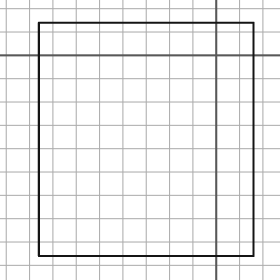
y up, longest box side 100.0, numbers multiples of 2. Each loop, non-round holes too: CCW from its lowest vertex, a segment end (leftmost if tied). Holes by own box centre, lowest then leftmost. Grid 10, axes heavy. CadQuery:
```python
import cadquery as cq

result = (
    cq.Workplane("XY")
    .moveTo(-76.0, -86.0)
    .lineTo(16.0, -86.0)
    .lineTo(16.0, 14.0)
    .lineTo(-76.0, 14.0)
    .close()
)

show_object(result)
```